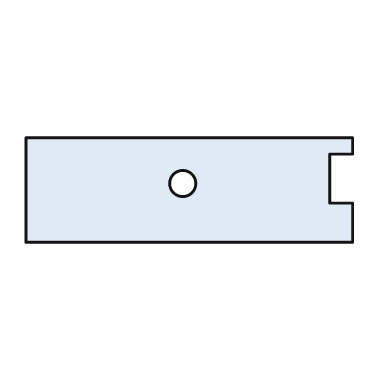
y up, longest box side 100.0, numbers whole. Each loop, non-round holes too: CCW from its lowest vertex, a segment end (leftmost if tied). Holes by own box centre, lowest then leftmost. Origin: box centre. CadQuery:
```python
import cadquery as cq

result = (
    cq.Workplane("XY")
    .moveTo(-50.0, -16.0)
    .lineTo(50.0, -16.0)
    .lineTo(50.0, -4.0)
    .lineTo(43.0, -4.0)
    .lineTo(43.0, 11.0)
    .lineTo(50.0, 11.0)
    .lineTo(50.0, 16.0)
    .lineTo(-50.0, 16.0)
    .close()
    .moveTo(-2.0, 2.0)
    .circle(4.0)
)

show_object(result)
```